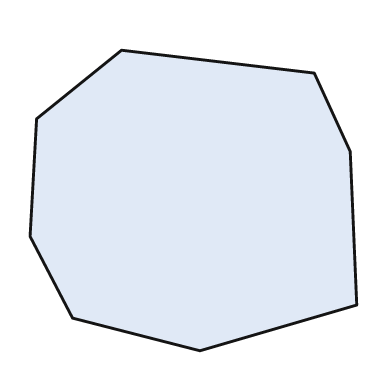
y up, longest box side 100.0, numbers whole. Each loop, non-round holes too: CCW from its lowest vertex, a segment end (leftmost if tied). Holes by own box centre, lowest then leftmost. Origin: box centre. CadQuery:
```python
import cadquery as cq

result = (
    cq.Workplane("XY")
    .moveTo(2.0, -46.0)
    .lineTo(50.0, -32.0)
    .lineTo(48.0, 15.0)
    .lineTo(37.0, 39.0)
    .lineTo(-22.0, 46.0)
    .lineTo(-48.0, 25.0)
    .lineTo(-50.0, -11.0)
    .lineTo(-37.0, -36.0)
    .close()
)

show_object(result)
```